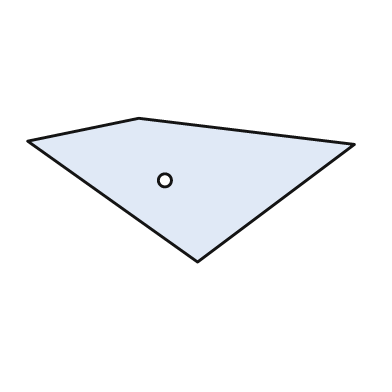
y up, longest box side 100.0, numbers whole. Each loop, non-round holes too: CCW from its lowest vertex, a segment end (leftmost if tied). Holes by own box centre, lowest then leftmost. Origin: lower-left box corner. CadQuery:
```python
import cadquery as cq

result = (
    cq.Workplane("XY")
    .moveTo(52.0, 0.0)
    .lineTo(100.0, 36.0)
    .lineTo(34.0, 44.0)
    .lineTo(0.0, 37.0)
    .close()
    .moveTo(42.0, 25.0)
    .circle(2.0)
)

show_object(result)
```